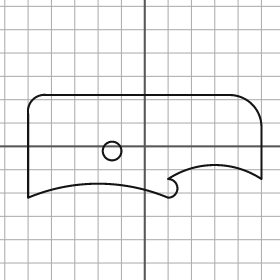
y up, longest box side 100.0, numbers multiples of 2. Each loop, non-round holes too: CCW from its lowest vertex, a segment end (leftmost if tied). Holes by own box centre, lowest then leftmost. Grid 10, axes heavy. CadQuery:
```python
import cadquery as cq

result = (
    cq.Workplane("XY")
    .moveTo(-50.0, -22.0)
    .threePointArc((-20.0, -16.0), (10.0, -22.0))
    .threePointArc((14.0, -18.0), (10.0, -14.0))
    .threePointArc((30.0, -8.0), (50.0, -14.0))
    .lineTo(50.0, 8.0)
    .threePointArc((46.0, 18.0), (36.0, 22.0))
    .lineTo(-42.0, 22.0)
    .threePointArc((-48.0, 20.0), (-50.0, 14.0))
    .close()
    .moveTo(-14.0, -2.0)
    .circle(4.0)
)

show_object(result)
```